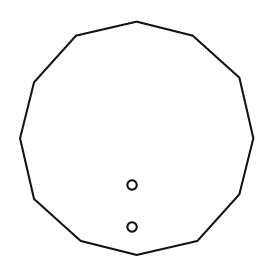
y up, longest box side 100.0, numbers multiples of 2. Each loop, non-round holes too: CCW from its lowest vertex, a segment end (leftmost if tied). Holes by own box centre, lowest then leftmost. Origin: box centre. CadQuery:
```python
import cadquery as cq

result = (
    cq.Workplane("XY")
    .moveTo(0.0, -50.0)
    .lineTo(26.0, -44.0)
    .lineTo(44.0, -24.0)
    .lineTo(50.0, 0.0)
    .lineTo(44.0, 26.0)
    .lineTo(24.0, 44.0)
    .lineTo(0.0, 50.0)
    .lineTo(-26.0, 44.0)
    .lineTo(-44.0, 24.0)
    .lineTo(-50.0, 0.0)
    .lineTo(-44.0, -26.0)
    .lineTo(-24.0, -44.0)
    .close()
    .moveTo(-2.0, -38.0)
    .circle(2.0)
    .moveTo(-2.0, -20.0)
    .circle(2.0)
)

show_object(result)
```